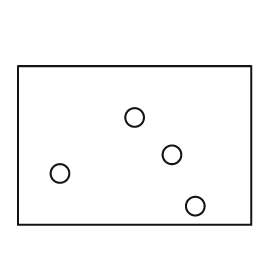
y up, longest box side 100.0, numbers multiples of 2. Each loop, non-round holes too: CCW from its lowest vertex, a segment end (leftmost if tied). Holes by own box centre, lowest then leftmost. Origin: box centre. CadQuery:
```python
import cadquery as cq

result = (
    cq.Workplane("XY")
    .moveTo(-50.0, -34.0)
    .lineTo(50.0, -34.0)
    .lineTo(50.0, 34.0)
    .lineTo(-50.0, 34.0)
    .close()
    .moveTo(26.0, -26.0)
    .circle(4.0)
    .moveTo(-32.0, -12.0)
    .circle(4.0)
    .moveTo(16.0, -4.0)
    .circle(4.0)
    .moveTo(0.0, 12.0)
    .circle(4.0)
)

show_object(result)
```